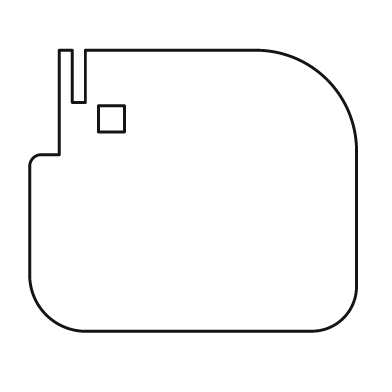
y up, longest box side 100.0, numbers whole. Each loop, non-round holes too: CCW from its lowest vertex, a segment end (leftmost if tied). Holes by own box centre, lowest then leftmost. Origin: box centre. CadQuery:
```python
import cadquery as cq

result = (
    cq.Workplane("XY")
    .moveTo(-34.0, -43.0)
    .lineTo(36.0, -43.0)
    .threePointArc((46.0, -39.0), (50.0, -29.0))
    .lineTo(50.0, 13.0)
    .threePointArc((41.0, 34.0), (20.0, 43.0))
    .lineTo(-33.0, 43.0)
    .lineTo(-33.0, 27.0)
    .lineTo(-37.0, 27.0)
    .lineTo(-37.0, 43.0)
    .lineTo(-41.0, 43.0)
    .lineTo(-41.0, 11.0)
    .lineTo(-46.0, 11.0)
    .threePointArc((-49.0, 10.0), (-50.0, 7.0))
    .lineTo(-50.0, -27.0)
    .threePointArc((-45.0, -38.0), (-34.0, -43.0))
    .close()
    .moveTo(-29.0, 18.0)
    .lineTo(-21.0, 18.0)
    .lineTo(-21.0, 26.0)
    .lineTo(-29.0, 26.0)
    .close()
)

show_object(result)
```